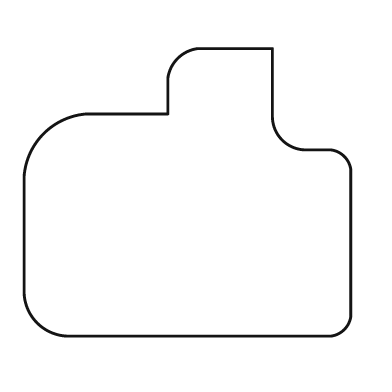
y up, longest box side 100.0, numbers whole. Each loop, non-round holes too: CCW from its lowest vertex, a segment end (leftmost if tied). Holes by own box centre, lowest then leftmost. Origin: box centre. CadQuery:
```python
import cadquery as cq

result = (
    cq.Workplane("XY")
    .moveTo(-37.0, -44.0)
    .lineTo(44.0, -44.0)
    .threePointArc((48.0, -42.0), (50.0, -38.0))
    .lineTo(50.0, 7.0)
    .threePointArc((48.0, 11.0), (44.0, 13.0))
    .lineTo(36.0, 13.0)
    .threePointArc((29.0, 16.0), (26.0, 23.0))
    .lineTo(26.0, 44.0)
    .lineTo(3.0, 44.0)
    .threePointArc((-3.0, 41.0), (-6.0, 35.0))
    .lineTo(-6.0, 24.0)
    .lineTo(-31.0, 24.0)
    .threePointArc((-44.0, 18.0), (-50.0, 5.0))
    .lineTo(-50.0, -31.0)
    .threePointArc((-46.0, -40.0), (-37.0, -44.0))
    .close()
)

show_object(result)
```